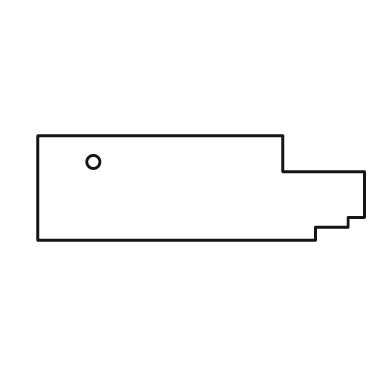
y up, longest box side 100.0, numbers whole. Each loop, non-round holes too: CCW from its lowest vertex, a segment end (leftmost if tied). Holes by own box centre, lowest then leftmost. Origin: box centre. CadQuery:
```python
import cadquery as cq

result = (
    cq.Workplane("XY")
    .moveTo(-50.0, -16.0)
    .lineTo(35.0, -16.0)
    .lineTo(35.0, -12.0)
    .lineTo(45.0, -12.0)
    .lineTo(45.0, -9.0)
    .lineTo(50.0, -9.0)
    .lineTo(50.0, 5.0)
    .lineTo(25.0, 5.0)
    .lineTo(25.0, 16.0)
    .lineTo(-50.0, 16.0)
    .close()
    .moveTo(-33.0, 8.0)
    .circle(2.0)
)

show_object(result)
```